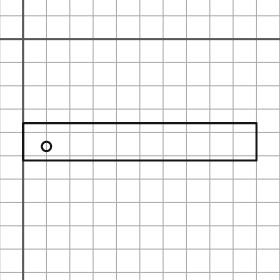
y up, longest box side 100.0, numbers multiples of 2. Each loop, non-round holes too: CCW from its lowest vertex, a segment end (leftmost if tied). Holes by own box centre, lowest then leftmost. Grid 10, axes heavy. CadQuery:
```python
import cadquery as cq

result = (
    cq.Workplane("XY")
    .moveTo(0.0, -52.0)
    .lineTo(100.0, -52.0)
    .lineTo(100.0, -36.0)
    .lineTo(0.0, -36.0)
    .close()
    .moveTo(10.0, -46.0)
    .circle(2.0)
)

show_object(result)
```